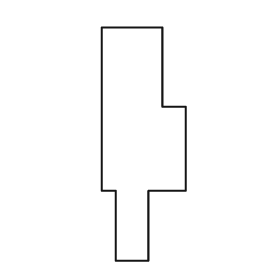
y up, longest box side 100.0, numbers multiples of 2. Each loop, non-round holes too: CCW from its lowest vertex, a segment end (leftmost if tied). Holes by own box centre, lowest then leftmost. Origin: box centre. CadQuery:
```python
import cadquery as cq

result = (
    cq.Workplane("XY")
    .moveTo(-12.0, -50.0)
    .lineTo(2.0, -50.0)
    .lineTo(2.0, -20.0)
    .lineTo(18.0, -20.0)
    .lineTo(18.0, 16.0)
    .lineTo(8.0, 16.0)
    .lineTo(8.0, 50.0)
    .lineTo(-18.0, 50.0)
    .lineTo(-18.0, -20.0)
    .lineTo(-12.0, -20.0)
    .close()
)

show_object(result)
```